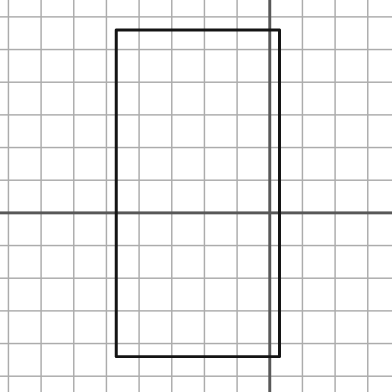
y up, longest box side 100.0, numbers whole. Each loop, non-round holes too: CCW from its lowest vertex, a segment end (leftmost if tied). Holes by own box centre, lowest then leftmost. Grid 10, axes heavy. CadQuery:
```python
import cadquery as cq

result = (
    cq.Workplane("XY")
    .moveTo(-47.0, -44.0)
    .lineTo(3.0, -44.0)
    .lineTo(3.0, 56.0)
    .lineTo(-47.0, 56.0)
    .close()
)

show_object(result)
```